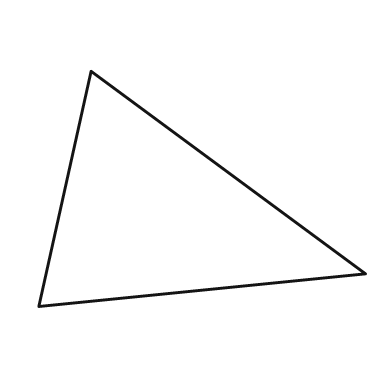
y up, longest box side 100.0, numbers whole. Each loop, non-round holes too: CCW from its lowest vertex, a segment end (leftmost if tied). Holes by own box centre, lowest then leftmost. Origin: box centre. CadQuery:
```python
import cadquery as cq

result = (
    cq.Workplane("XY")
    .moveTo(-50.0, -36.0)
    .lineTo(50.0, -26.0)
    .lineTo(-34.0, 36.0)
    .close()
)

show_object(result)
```